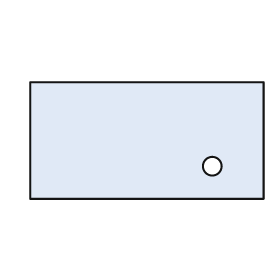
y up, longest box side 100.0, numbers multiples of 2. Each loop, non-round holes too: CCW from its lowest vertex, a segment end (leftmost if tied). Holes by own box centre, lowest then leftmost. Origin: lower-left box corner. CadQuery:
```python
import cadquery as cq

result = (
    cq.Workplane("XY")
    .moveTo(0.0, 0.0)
    .lineTo(100.0, 0.0)
    .lineTo(100.0, 50.0)
    .lineTo(0.0, 50.0)
    .close()
    .moveTo(78.0, 14.0)
    .circle(4.0)
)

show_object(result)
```